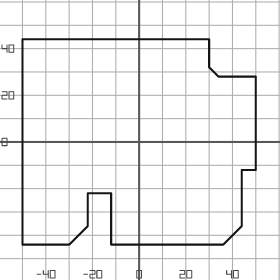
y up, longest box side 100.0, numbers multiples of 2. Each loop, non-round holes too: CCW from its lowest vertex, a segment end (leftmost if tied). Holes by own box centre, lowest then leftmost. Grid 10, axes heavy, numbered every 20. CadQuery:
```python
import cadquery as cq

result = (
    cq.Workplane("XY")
    .moveTo(-50.0, -44.0)
    .lineTo(-30.0, -44.0)
    .lineTo(-22.0, -36.0)
    .lineTo(-22.0, -22.0)
    .lineTo(-12.0, -22.0)
    .lineTo(-12.0, -44.0)
    .lineTo(36.0, -44.0)
    .lineTo(44.0, -36.0)
    .lineTo(44.0, -12.0)
    .lineTo(50.0, -12.0)
    .lineTo(50.0, 28.0)
    .lineTo(34.0, 28.0)
    .lineTo(30.0, 32.0)
    .lineTo(30.0, 44.0)
    .lineTo(-50.0, 44.0)
    .close()
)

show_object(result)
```